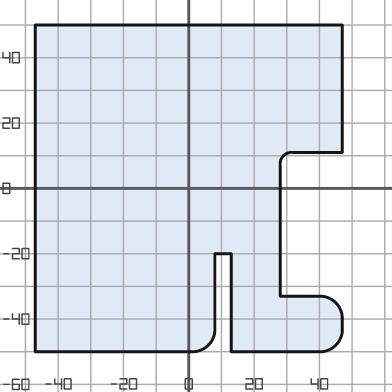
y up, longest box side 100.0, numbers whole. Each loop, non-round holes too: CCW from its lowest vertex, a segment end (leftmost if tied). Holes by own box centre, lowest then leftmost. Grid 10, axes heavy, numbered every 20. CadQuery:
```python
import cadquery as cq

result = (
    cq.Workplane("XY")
    .moveTo(-47.0, -50.0)
    .lineTo(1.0, -50.0)
    .threePointArc((6.0, -48.0), (8.0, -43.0))
    .lineTo(8.0, -20.0)
    .lineTo(13.0, -20.0)
    .lineTo(13.0, -50.0)
    .lineTo(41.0, -50.0)
    .threePointArc((45.0, -48.0), (47.0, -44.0))
    .lineTo(47.0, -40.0)
    .threePointArc((45.0, -35.0), (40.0, -33.0))
    .lineTo(28.0, -33.0)
    .lineTo(28.0, 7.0)
    .threePointArc((29.0, 10.0), (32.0, 11.0))
    .lineTo(47.0, 11.0)
    .lineTo(47.0, 50.0)
    .lineTo(-47.0, 50.0)
    .close()
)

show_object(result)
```